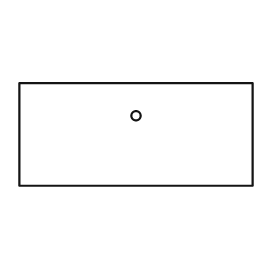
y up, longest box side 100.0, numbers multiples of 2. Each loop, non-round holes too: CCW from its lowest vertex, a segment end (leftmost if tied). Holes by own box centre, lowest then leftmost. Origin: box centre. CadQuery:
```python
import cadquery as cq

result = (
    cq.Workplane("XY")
    .moveTo(-50.0, -22.0)
    .lineTo(50.0, -22.0)
    .lineTo(50.0, 22.0)
    .lineTo(-50.0, 22.0)
    .close()
    .moveTo(0.0, 8.0)
    .circle(2.0)
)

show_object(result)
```